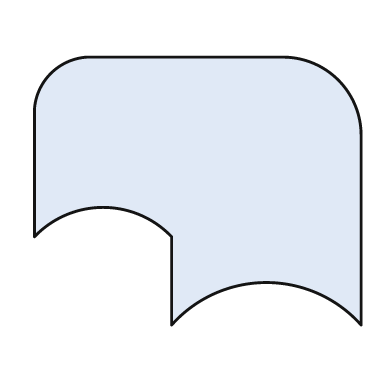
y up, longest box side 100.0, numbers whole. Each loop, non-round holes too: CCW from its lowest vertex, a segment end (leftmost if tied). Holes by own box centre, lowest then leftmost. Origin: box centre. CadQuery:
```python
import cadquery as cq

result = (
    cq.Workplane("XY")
    .moveTo(-8.0, -41.0)
    .threePointArc((21.0, -28.0), (50.0, -41.0))
    .lineTo(50.0, 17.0)
    .threePointArc((43.0, 34.0), (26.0, 41.0))
    .lineTo(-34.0, 41.0)
    .threePointArc((-45.0, 36.0), (-50.0, 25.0))
    .lineTo(-50.0, -14.0)
    .threePointArc((-29.0, -5.0), (-8.0, -14.0))
    .close()
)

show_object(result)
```